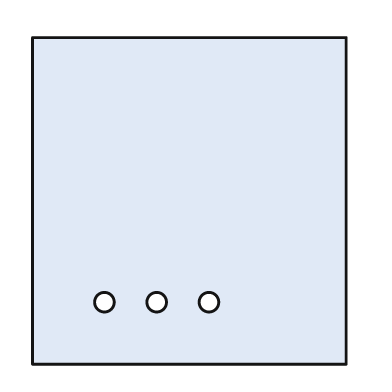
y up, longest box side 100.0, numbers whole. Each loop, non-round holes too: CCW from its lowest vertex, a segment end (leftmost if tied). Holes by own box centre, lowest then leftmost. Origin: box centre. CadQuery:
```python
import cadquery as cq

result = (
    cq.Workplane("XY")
    .moveTo(-48.0, -50.0)
    .lineTo(48.0, -50.0)
    .lineTo(48.0, 50.0)
    .lineTo(-48.0, 50.0)
    .close()
    .moveTo(-26.0, -31.0)
    .circle(3.0)
    .moveTo(-10.0, -31.0)
    .circle(3.0)
    .moveTo(6.0, -31.0)
    .circle(3.0)
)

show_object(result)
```